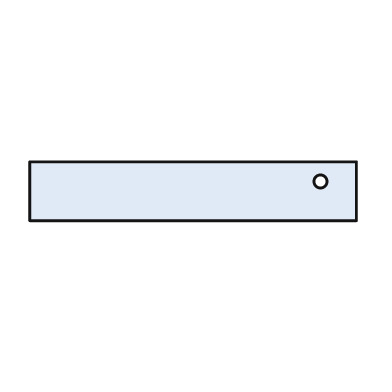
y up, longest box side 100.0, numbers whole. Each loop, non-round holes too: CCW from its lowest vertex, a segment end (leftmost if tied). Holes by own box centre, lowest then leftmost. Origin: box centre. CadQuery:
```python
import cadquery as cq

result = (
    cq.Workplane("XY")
    .moveTo(-50.0, -9.0)
    .lineTo(50.0, -9.0)
    .lineTo(50.0, 9.0)
    .lineTo(-50.0, 9.0)
    .close()
    .moveTo(39.0, 3.0)
    .circle(2.0)
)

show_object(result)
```